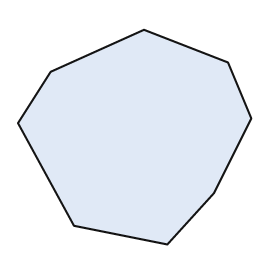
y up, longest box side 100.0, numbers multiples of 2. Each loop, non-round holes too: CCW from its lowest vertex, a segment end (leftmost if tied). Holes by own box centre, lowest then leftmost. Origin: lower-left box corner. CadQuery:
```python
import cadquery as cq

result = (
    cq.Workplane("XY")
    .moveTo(64.0, 0.0)
    .lineTo(84.0, 22.0)
    .lineTo(100.0, 54.0)
    .lineTo(90.0, 78.0)
    .lineTo(54.0, 92.0)
    .lineTo(14.0, 74.0)
    .lineTo(0.0, 52.0)
    .lineTo(24.0, 8.0)
    .close()
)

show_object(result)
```